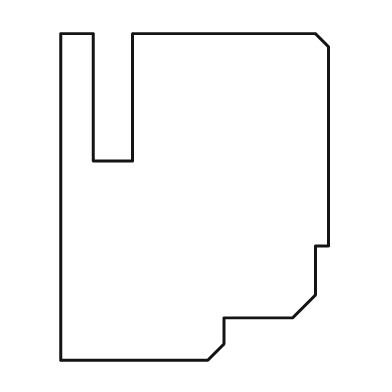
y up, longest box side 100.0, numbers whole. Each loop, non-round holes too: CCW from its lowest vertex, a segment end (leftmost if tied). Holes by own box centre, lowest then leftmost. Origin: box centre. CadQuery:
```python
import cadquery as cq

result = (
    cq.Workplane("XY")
    .moveTo(-41.0, -50.0)
    .lineTo(4.0, -50.0)
    .lineTo(9.0, -45.0)
    .lineTo(9.0, -37.0)
    .lineTo(30.0, -37.0)
    .lineTo(37.0, -30.0)
    .lineTo(37.0, -15.0)
    .lineTo(41.0, -15.0)
    .lineTo(41.0, 46.0)
    .lineTo(37.0, 50.0)
    .lineTo(-19.0, 50.0)
    .lineTo(-19.0, 11.0)
    .lineTo(-31.0, 11.0)
    .lineTo(-31.0, 50.0)
    .lineTo(-41.0, 50.0)
    .close()
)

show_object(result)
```